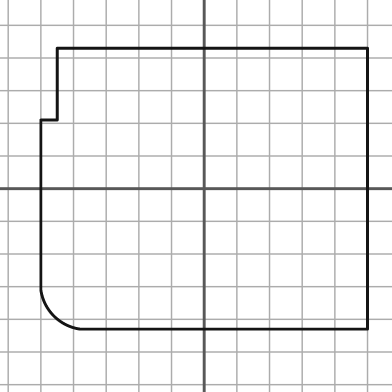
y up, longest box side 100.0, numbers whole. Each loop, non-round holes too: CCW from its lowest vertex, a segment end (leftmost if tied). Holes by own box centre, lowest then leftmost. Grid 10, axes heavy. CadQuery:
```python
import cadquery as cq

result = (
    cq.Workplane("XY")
    .moveTo(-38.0, -43.0)
    .lineTo(50.0, -43.0)
    .lineTo(50.0, 43.0)
    .lineTo(-45.0, 43.0)
    .lineTo(-45.0, 21.0)
    .lineTo(-50.0, 21.0)
    .lineTo(-50.0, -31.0)
    .threePointArc((-46.0, -39.0), (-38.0, -43.0))
    .close()
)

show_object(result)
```